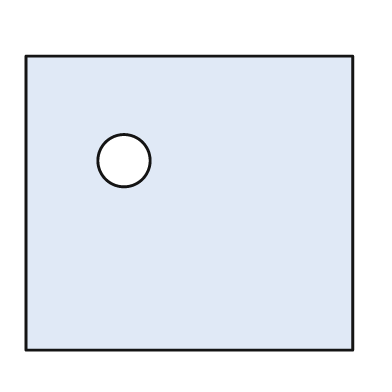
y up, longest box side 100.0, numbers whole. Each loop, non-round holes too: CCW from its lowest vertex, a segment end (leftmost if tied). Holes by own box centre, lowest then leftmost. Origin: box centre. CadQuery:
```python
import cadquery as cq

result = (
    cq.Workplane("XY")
    .moveTo(-50.0, -45.0)
    .lineTo(50.0, -45.0)
    .lineTo(50.0, 45.0)
    .lineTo(-50.0, 45.0)
    .close()
    .moveTo(-20.0, 13.0)
    .circle(8.0)
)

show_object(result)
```